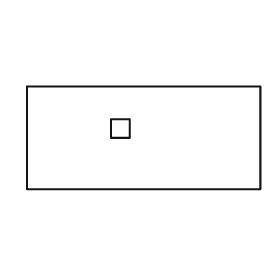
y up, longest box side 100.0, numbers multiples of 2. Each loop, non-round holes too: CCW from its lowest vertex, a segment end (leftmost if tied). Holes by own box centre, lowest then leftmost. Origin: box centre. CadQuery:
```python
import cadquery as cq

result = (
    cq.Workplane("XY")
    .moveTo(-50.0, -22.0)
    .lineTo(50.0, -22.0)
    .lineTo(50.0, 22.0)
    .lineTo(-50.0, 22.0)
    .close()
    .moveTo(-14.0, 0.0)
    .lineTo(-6.0, 0.0)
    .lineTo(-6.0, 8.0)
    .lineTo(-14.0, 8.0)
    .close()
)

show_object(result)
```